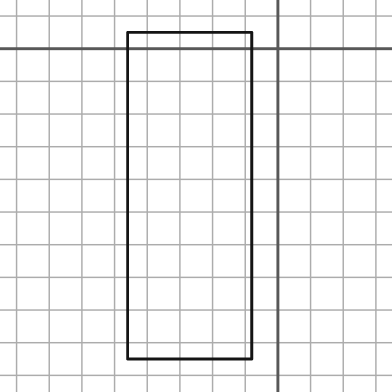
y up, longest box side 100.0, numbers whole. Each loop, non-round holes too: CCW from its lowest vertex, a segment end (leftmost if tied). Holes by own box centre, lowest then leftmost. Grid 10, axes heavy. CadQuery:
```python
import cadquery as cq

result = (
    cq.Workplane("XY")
    .moveTo(-46.0, -95.0)
    .lineTo(-8.0, -95.0)
    .lineTo(-8.0, 5.0)
    .lineTo(-46.0, 5.0)
    .close()
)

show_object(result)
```